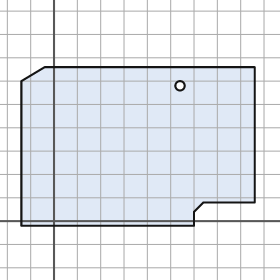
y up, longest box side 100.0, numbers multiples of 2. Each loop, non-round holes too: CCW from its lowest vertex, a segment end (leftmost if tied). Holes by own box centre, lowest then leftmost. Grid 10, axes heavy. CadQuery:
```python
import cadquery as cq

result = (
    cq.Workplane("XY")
    .moveTo(-14.0, -2.0)
    .lineTo(60.0, -2.0)
    .lineTo(60.0, 4.0)
    .lineTo(64.0, 8.0)
    .lineTo(86.0, 8.0)
    .lineTo(86.0, 66.0)
    .lineTo(-4.0, 66.0)
    .lineTo(-14.0, 60.0)
    .close()
    .moveTo(54.0, 58.0)
    .circle(2.0)
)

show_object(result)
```